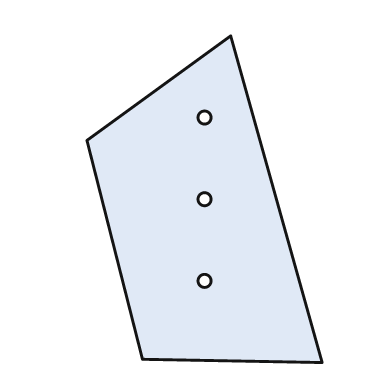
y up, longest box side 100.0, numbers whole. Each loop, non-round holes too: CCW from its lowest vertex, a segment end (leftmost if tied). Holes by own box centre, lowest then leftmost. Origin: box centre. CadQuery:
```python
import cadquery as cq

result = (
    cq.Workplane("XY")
    .moveTo(36.0, -50.0)
    .lineTo(8.0, 50.0)
    .lineTo(-36.0, 18.0)
    .lineTo(-19.0, -49.0)
    .close()
    .moveTo(0.0, -25.0)
    .circle(2.0)
    .moveTo(0.0, 0.0)
    .circle(2.0)
    .moveTo(0.0, 25.0)
    .circle(2.0)
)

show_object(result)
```